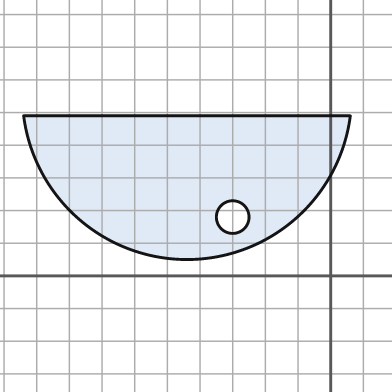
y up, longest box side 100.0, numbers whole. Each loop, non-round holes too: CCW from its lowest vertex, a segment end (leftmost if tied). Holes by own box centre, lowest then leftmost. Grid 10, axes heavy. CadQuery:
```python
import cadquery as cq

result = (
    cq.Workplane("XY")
    .moveTo(-94.0, 49.0)
    .threePointArc((-44.0, 5.0), (6.0, 49.0))
    .close()
    .moveTo(-30.0, 18.0)
    .circle(5.0)
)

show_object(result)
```